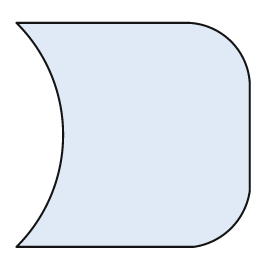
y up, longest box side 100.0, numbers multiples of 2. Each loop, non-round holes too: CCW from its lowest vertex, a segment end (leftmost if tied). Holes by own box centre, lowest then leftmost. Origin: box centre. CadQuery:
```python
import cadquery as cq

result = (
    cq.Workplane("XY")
    .moveTo(-50.0, -48.0)
    .lineTo(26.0, -48.0)
    .threePointArc((42.0, -40.0), (50.0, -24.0))
    .lineTo(50.0, 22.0)
    .threePointArc((42.0, 40.0), (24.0, 48.0))
    .lineTo(-50.0, 48.0)
    .threePointArc((-30.0, 0.0), (-50.0, -48.0))
    .close()
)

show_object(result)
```